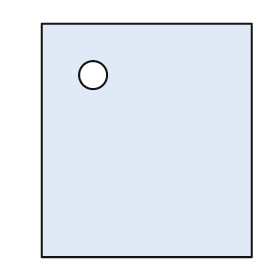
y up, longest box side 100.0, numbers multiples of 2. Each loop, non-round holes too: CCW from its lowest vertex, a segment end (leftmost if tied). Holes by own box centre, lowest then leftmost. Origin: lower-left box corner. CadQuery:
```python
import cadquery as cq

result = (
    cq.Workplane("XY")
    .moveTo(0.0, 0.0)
    .lineTo(90.0, 0.0)
    .lineTo(90.0, 100.0)
    .lineTo(0.0, 100.0)
    .close()
    .moveTo(22.0, 78.0)
    .circle(6.0)
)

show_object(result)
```